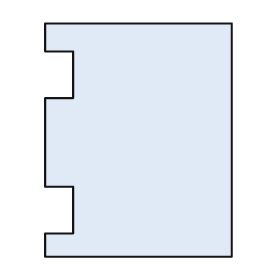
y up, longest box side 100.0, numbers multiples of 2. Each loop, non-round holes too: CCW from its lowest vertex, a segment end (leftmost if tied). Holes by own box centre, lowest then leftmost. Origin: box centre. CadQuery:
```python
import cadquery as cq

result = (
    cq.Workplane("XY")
    .moveTo(-40.0, -50.0)
    .lineTo(40.0, -50.0)
    .lineTo(40.0, 50.0)
    .lineTo(-40.0, 50.0)
    .lineTo(-40.0, 38.0)
    .lineTo(-28.0, 38.0)
    .lineTo(-28.0, 18.0)
    .lineTo(-40.0, 18.0)
    .lineTo(-40.0, -20.0)
    .lineTo(-28.0, -20.0)
    .lineTo(-28.0, -40.0)
    .lineTo(-40.0, -40.0)
    .close()
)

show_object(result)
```